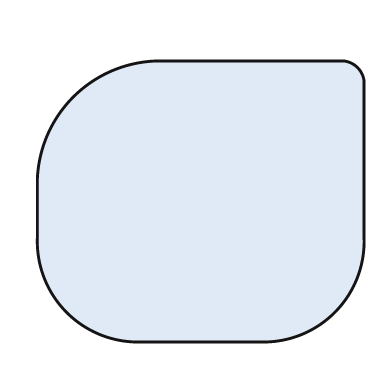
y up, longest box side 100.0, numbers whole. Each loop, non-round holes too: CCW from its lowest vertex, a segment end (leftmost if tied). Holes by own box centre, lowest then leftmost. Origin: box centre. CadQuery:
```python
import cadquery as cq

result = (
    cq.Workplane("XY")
    .moveTo(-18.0, -43.0)
    .lineTo(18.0, -43.0)
    .threePointArc((41.0, -34.0), (50.0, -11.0))
    .lineTo(50.0, 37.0)
    .threePointArc((48.0, 41.0), (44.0, 43.0))
    .lineTo(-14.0, 43.0)
    .threePointArc((-39.0, 32.0), (-50.0, 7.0))
    .lineTo(-50.0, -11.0)
    .threePointArc((-41.0, -34.0), (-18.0, -43.0))
    .close()
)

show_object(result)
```